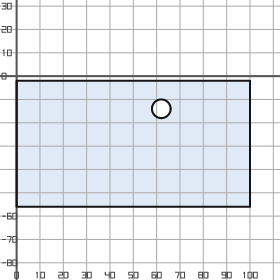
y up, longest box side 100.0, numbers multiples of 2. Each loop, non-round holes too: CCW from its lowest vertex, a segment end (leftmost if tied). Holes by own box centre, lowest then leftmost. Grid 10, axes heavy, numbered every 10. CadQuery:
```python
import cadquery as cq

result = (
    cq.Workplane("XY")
    .moveTo(0.0, -56.0)
    .lineTo(100.0, -56.0)
    .lineTo(100.0, -2.0)
    .lineTo(0.0, -2.0)
    .close()
    .moveTo(62.0, -14.0)
    .circle(4.0)
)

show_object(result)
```